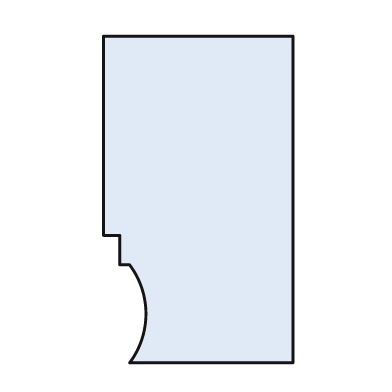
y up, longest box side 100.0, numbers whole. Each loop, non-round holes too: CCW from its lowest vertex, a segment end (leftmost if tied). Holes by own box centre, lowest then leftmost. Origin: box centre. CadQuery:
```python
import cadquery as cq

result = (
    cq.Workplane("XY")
    .moveTo(-21.0, -50.0)
    .lineTo(29.0, -50.0)
    .lineTo(29.0, 50.0)
    .lineTo(-29.0, 50.0)
    .lineTo(-29.0, -11.0)
    .lineTo(-24.0, -11.0)
    .lineTo(-24.0, -20.0)
    .lineTo(-21.0, -20.0)
    .threePointArc((-16.0, -35.0), (-21.0, -50.0))
    .close()
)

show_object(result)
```